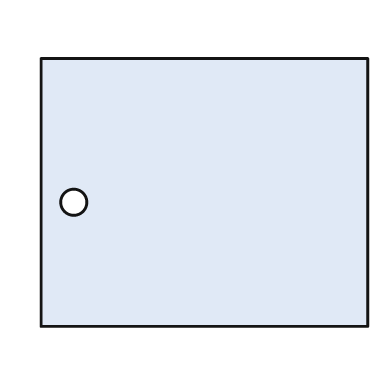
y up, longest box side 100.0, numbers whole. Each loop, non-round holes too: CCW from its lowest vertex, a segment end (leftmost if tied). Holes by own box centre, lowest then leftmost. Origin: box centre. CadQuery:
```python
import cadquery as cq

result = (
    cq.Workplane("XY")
    .moveTo(-50.0, -41.0)
    .lineTo(50.0, -41.0)
    .lineTo(50.0, 41.0)
    .lineTo(-50.0, 41.0)
    .close()
    .moveTo(-40.0, -3.0)
    .circle(4.0)
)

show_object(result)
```